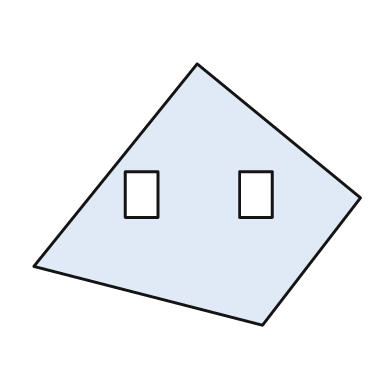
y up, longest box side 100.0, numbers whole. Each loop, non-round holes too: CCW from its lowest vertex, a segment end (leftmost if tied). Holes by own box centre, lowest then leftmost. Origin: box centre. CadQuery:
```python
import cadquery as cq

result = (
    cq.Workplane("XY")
    .moveTo(20.0, -40.0)
    .lineTo(50.0, -1.0)
    .lineTo(0.0, 40.0)
    .lineTo(-50.0, -22.0)
    .close()
    .moveTo(-22.0, -7.0)
    .lineTo(-12.0, -7.0)
    .lineTo(-12.0, 7.0)
    .lineTo(-22.0, 7.0)
    .close()
    .moveTo(13.0, -7.0)
    .lineTo(23.0, -7.0)
    .lineTo(23.0, 7.0)
    .lineTo(13.0, 7.0)
    .close()
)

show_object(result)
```